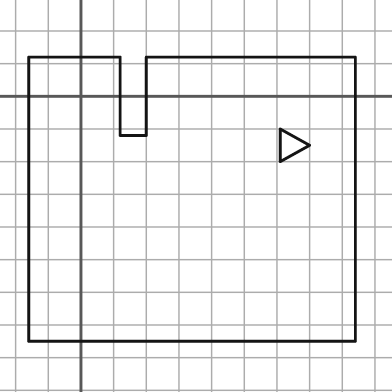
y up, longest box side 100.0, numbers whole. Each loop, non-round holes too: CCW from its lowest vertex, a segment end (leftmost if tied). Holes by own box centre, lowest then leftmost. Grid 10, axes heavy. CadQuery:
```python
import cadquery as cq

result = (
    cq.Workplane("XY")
    .moveTo(-16.0, -75.0)
    .lineTo(84.0, -75.0)
    .lineTo(84.0, 12.0)
    .lineTo(20.0, 12.0)
    .lineTo(20.0, -12.0)
    .lineTo(12.0, -12.0)
    .lineTo(12.0, 12.0)
    .lineTo(-16.0, 12.0)
    .close()
    .moveTo(61.0, -20.0)
    .lineTo(70.0, -15.0)
    .lineTo(61.0, -10.0)
    .close()
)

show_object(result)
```